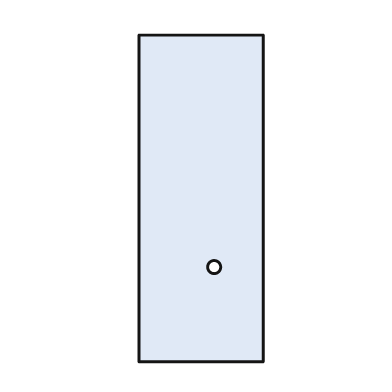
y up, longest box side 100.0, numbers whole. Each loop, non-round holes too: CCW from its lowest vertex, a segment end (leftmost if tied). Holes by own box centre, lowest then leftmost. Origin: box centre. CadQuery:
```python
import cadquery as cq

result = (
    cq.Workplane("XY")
    .moveTo(-19.0, -50.0)
    .lineTo(19.0, -50.0)
    .lineTo(19.0, 50.0)
    .lineTo(-19.0, 50.0)
    .close()
    .moveTo(4.0, -21.0)
    .circle(2.0)
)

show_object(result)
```